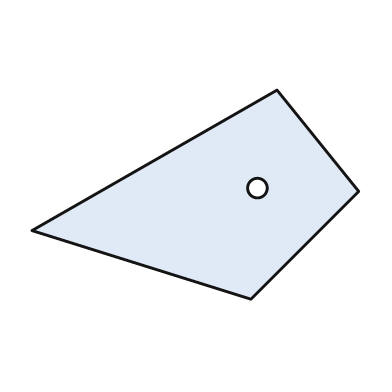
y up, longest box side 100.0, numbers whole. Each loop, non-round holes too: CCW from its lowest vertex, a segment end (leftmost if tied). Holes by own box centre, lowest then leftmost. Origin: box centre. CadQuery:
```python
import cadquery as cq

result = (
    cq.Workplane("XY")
    .moveTo(17.0, -32.0)
    .lineTo(50.0, 1.0)
    .lineTo(25.0, 32.0)
    .lineTo(-50.0, -11.0)
    .close()
    .moveTo(19.0, 2.0)
    .circle(3.0)
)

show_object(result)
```